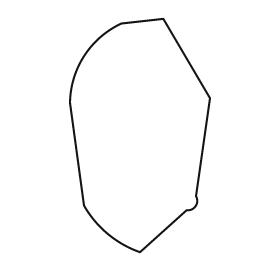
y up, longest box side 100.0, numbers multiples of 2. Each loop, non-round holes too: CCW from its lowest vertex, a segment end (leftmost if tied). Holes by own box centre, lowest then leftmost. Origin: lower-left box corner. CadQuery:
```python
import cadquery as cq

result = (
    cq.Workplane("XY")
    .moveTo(30.0, 0.0)
    .lineTo(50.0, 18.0)
    .threePointArc((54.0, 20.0), (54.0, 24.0))
    .lineTo(60.0, 66.0)
    .lineTo(40.0, 100.0)
    .lineTo(22.0, 98.0)
    .threePointArc((6.0, 84.0), (0.0, 64.0))
    .lineTo(6.0, 20.0)
    .threePointArc((16.0, 8.0), (30.0, 0.0))
    .close()
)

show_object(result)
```